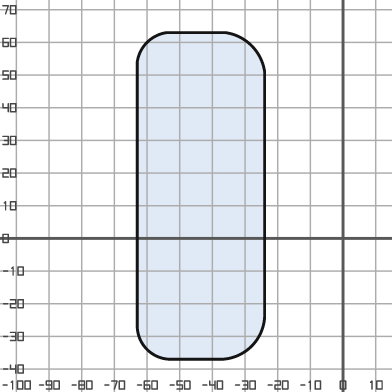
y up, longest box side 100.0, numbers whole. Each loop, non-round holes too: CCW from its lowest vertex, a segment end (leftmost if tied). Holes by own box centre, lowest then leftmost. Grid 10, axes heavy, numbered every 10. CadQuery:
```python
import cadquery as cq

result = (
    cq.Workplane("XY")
    .moveTo(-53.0, -37.0)
    .lineTo(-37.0, -37.0)
    .threePointArc((-28.0, -33.0), (-24.0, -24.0))
    .lineTo(-24.0, 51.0)
    .threePointArc((-28.0, 59.0), (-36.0, 63.0))
    .lineTo(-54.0, 63.0)
    .threePointArc((-60.0, 60.0), (-63.0, 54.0))
    .lineTo(-63.0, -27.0)
    .threePointArc((-60.0, -34.0), (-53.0, -37.0))
    .close()
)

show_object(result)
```